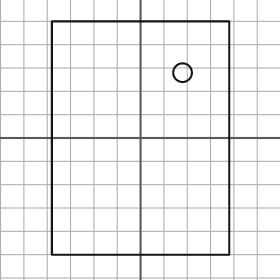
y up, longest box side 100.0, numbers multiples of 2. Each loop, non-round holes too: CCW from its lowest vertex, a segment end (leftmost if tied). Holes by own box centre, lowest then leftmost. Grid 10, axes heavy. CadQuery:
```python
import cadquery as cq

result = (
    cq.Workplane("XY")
    .moveTo(-38.0, -50.0)
    .lineTo(38.0, -50.0)
    .lineTo(38.0, 50.0)
    .lineTo(-38.0, 50.0)
    .close()
    .moveTo(18.0, 28.0)
    .circle(4.0)
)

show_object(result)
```